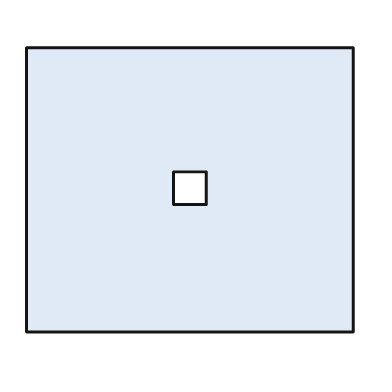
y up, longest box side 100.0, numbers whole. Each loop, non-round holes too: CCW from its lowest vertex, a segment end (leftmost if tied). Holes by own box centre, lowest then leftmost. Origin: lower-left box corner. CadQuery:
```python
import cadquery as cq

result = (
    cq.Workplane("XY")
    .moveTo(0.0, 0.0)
    .lineTo(100.0, 0.0)
    .lineTo(100.0, 87.0)
    .lineTo(0.0, 87.0)
    .close()
    .moveTo(45.0, 39.0)
    .lineTo(55.0, 39.0)
    .lineTo(55.0, 49.0)
    .lineTo(45.0, 49.0)
    .close()
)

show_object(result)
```